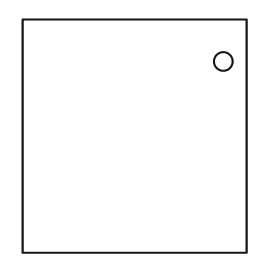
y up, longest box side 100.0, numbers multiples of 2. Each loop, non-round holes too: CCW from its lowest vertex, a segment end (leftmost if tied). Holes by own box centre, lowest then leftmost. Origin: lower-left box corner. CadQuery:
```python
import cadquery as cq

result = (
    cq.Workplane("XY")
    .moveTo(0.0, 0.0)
    .lineTo(96.0, 0.0)
    .lineTo(96.0, 100.0)
    .lineTo(0.0, 100.0)
    .close()
    .moveTo(86.0, 82.0)
    .circle(4.0)
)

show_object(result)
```